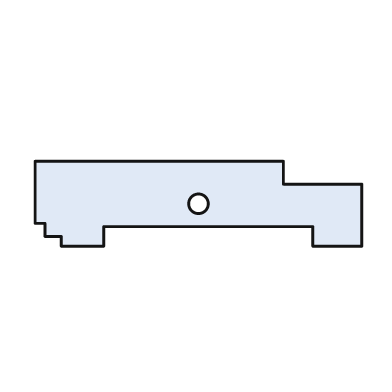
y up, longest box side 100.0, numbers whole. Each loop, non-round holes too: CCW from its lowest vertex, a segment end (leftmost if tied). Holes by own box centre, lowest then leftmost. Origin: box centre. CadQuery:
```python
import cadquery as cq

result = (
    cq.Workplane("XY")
    .moveTo(-42.0, -13.0)
    .lineTo(-29.0, -13.0)
    .lineTo(-29.0, -7.0)
    .lineTo(35.0, -7.0)
    .lineTo(35.0, -13.0)
    .lineTo(50.0, -13.0)
    .lineTo(50.0, 6.0)
    .lineTo(26.0, 6.0)
    .lineTo(26.0, 13.0)
    .lineTo(-50.0, 13.0)
    .lineTo(-50.0, -6.0)
    .lineTo(-47.0, -6.0)
    .lineTo(-47.0, -10.0)
    .lineTo(-42.0, -10.0)
    .close()
    .moveTo(0.0, 0.0)
    .circle(3.0)
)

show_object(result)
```